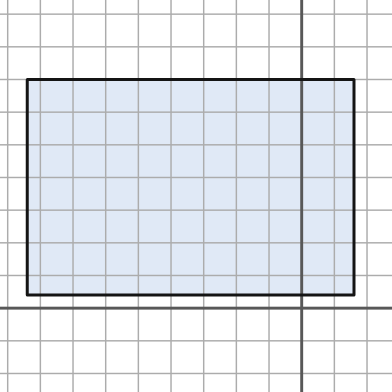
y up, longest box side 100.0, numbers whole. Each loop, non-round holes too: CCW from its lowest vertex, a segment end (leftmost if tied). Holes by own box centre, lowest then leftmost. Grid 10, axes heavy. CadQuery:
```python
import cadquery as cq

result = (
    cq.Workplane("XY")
    .moveTo(-84.0, 4.0)
    .lineTo(16.0, 4.0)
    .lineTo(16.0, 70.0)
    .lineTo(-84.0, 70.0)
    .close()
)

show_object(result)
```